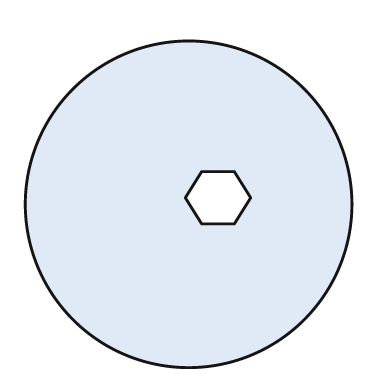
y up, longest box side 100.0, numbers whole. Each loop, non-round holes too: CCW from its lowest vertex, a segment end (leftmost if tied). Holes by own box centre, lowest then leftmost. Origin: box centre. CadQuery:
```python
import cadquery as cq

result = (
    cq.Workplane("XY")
    .moveTo(0.0, 0.0)
    .circle(50.0)
    .moveTo(4.0, -6.0)
    .lineTo(14.0, -6.0)
    .lineTo(19.0, 2.0)
    .lineTo(14.0, 10.0)
    .lineTo(4.0, 10.0)
    .lineTo(-1.0, 2.0)
    .close()
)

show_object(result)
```